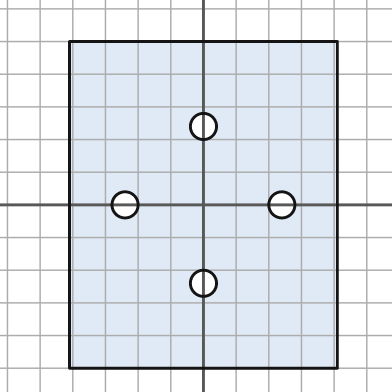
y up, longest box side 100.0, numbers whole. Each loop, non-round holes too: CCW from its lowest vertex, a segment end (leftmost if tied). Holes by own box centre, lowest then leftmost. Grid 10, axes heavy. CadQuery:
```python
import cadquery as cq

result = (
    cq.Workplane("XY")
    .moveTo(-41.0, -50.0)
    .lineTo(41.0, -50.0)
    .lineTo(41.0, 50.0)
    .lineTo(-41.0, 50.0)
    .close()
    .moveTo(0.0, -24.0)
    .circle(4.0)
    .moveTo(-24.0, 0.0)
    .circle(4.0)
    .moveTo(24.0, 0.0)
    .circle(4.0)
    .moveTo(0.0, 24.0)
    .circle(4.0)
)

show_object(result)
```